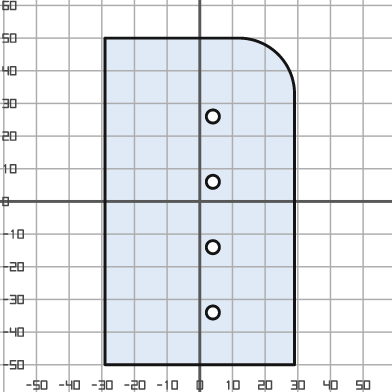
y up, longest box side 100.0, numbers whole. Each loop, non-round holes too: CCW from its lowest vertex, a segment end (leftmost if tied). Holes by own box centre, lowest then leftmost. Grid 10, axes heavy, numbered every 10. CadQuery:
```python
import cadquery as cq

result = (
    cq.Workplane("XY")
    .moveTo(-29.0, -50.0)
    .lineTo(29.0, -50.0)
    .lineTo(29.0, 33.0)
    .threePointArc((24.0, 45.0), (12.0, 50.0))
    .lineTo(-29.0, 50.0)
    .close()
    .moveTo(4.0, -34.0)
    .circle(2.0)
    .moveTo(4.0, -14.0)
    .circle(2.0)
    .moveTo(4.0, 6.0)
    .circle(2.0)
    .moveTo(4.0, 26.0)
    .circle(2.0)
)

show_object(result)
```